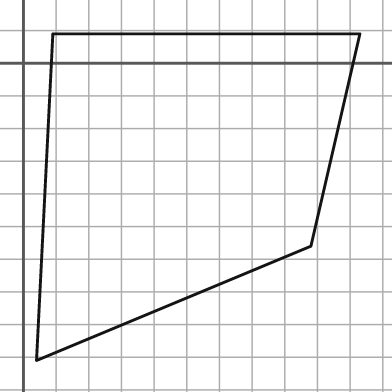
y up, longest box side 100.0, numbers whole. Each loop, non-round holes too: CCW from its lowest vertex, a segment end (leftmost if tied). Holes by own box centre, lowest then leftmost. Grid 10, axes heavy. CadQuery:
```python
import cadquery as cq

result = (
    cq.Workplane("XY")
    .moveTo(4.0, -91.0)
    .lineTo(88.0, -56.0)
    .lineTo(103.0, 9.0)
    .lineTo(9.0, 9.0)
    .close()
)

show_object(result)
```